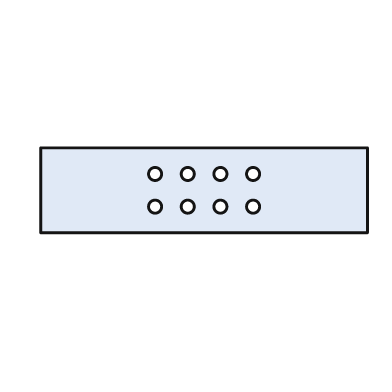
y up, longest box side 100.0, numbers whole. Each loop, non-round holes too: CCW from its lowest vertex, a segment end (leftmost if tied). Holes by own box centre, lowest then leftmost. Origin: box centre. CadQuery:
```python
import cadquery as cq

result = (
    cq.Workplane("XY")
    .moveTo(-50.0, -13.0)
    .lineTo(50.0, -13.0)
    .lineTo(50.0, 13.0)
    .lineTo(-50.0, 13.0)
    .close()
    .moveTo(-15.0, -5.0)
    .circle(2.0)
    .moveTo(-5.0, -5.0)
    .circle(2.0)
    .moveTo(5.0, -5.0)
    .circle(2.0)
    .moveTo(15.0, -5.0)
    .circle(2.0)
    .moveTo(-15.0, 5.0)
    .circle(2.0)
    .moveTo(-5.0, 5.0)
    .circle(2.0)
    .moveTo(5.0, 5.0)
    .circle(2.0)
    .moveTo(15.0, 5.0)
    .circle(2.0)
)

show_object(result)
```